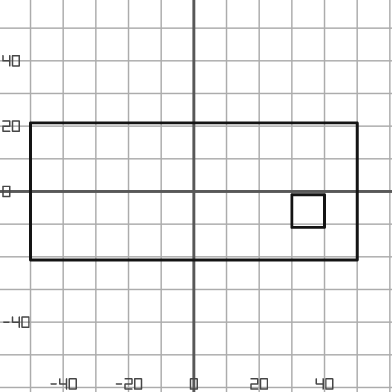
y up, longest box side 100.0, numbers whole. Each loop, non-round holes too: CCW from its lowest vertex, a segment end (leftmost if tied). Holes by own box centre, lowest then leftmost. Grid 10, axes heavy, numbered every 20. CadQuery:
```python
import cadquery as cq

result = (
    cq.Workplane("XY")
    .moveTo(-50.0, -21.0)
    .lineTo(50.0, -21.0)
    .lineTo(50.0, 21.0)
    .lineTo(-50.0, 21.0)
    .close()
    .moveTo(30.0, -11.0)
    .lineTo(40.0, -11.0)
    .lineTo(40.0, -1.0)
    .lineTo(30.0, -1.0)
    .close()
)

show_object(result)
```